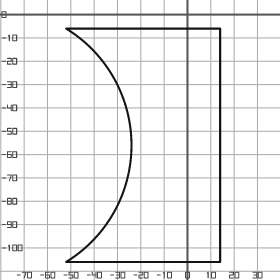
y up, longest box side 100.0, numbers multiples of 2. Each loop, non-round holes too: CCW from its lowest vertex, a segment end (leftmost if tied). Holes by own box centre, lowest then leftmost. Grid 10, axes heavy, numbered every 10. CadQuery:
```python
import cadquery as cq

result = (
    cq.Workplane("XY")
    .moveTo(-52.0, -106.0)
    .lineTo(14.0, -106.0)
    .lineTo(14.0, -6.0)
    .lineTo(-52.0, -6.0)
    .threePointArc((-24.0, -56.0), (-52.0, -106.0))
    .close()
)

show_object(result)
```